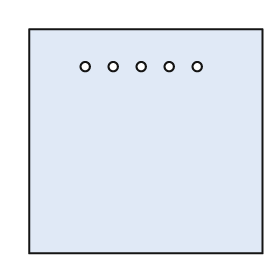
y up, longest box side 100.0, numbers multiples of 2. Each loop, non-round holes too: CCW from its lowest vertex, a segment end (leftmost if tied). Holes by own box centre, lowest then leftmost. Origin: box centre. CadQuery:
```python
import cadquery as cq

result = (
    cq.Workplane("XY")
    .moveTo(-50.0, -48.0)
    .lineTo(50.0, -48.0)
    .lineTo(50.0, 48.0)
    .lineTo(-50.0, 48.0)
    .close()
    .moveTo(-26.0, 32.0)
    .circle(2.0)
    .moveTo(-14.0, 32.0)
    .circle(2.0)
    .moveTo(-2.0, 32.0)
    .circle(2.0)
    .moveTo(10.0, 32.0)
    .circle(2.0)
    .moveTo(22.0, 32.0)
    .circle(2.0)
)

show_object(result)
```